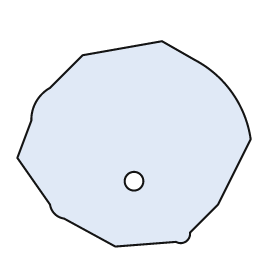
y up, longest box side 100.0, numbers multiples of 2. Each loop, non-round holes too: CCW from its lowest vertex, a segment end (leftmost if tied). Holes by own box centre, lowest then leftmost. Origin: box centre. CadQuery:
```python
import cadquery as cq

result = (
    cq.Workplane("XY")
    .moveTo(-8.0, -44.0)
    .lineTo(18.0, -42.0)
    .threePointArc((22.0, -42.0), (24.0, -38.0))
    .lineTo(36.0, -26.0)
    .lineTo(50.0, 2.0)
    .threePointArc((42.0, 22.0), (26.0, 36.0))
    .lineTo(12.0, 44.0)
    .lineTo(-22.0, 38.0)
    .lineTo(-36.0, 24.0)
    .threePointArc((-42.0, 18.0), (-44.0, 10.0))
    .lineTo(-50.0, -6.0)
    .lineTo(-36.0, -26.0)
    .threePointArc((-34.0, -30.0), (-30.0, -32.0))
    .close()
    .moveTo(0.0, -16.0)
    .circle(4.0)
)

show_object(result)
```